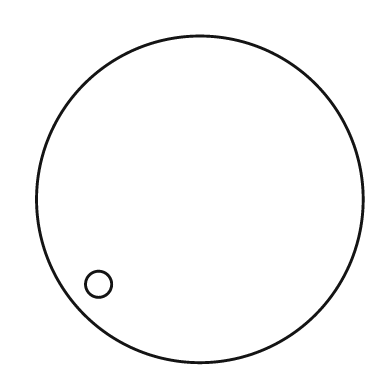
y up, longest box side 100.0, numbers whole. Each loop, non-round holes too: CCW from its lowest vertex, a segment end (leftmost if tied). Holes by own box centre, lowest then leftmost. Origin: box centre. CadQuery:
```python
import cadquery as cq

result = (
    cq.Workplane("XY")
    .moveTo(0.0, 0.0)
    .circle(50.0)
    .moveTo(-31.0, -26.0)
    .circle(4.0)
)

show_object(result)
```